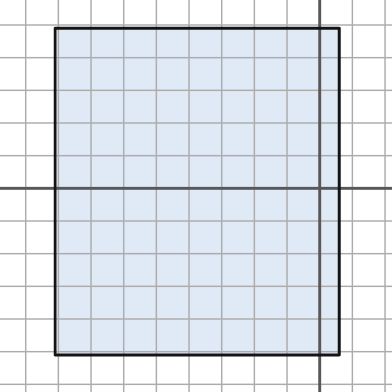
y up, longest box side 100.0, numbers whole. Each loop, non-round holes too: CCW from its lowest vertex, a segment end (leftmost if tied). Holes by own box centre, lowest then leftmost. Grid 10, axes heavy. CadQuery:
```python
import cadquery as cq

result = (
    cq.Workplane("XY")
    .moveTo(-81.0, -51.0)
    .lineTo(6.0, -51.0)
    .lineTo(6.0, 49.0)
    .lineTo(-81.0, 49.0)
    .close()
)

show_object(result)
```